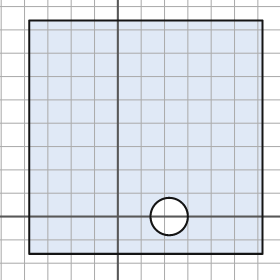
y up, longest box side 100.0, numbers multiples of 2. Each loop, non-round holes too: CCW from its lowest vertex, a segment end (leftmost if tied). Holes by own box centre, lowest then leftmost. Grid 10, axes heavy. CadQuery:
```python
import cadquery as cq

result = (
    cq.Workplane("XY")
    .moveTo(-38.0, -16.0)
    .lineTo(62.0, -16.0)
    .lineTo(62.0, 84.0)
    .lineTo(-38.0, 84.0)
    .close()
    .moveTo(22.0, 0.0)
    .circle(8.0)
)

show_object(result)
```